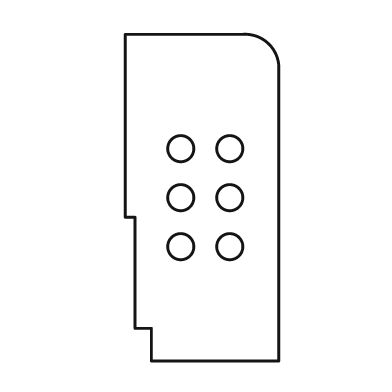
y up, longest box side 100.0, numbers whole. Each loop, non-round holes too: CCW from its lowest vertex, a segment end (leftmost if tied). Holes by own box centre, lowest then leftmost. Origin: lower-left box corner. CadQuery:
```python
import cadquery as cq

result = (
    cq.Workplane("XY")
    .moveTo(8.0, 0.0)
    .lineTo(47.0, 0.0)
    .lineTo(47.0, 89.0)
    .threePointArc((44.0, 97.0), (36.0, 100.0))
    .lineTo(0.0, 100.0)
    .lineTo(0.0, 44.0)
    .lineTo(3.0, 44.0)
    .lineTo(3.0, 10.0)
    .lineTo(8.0, 10.0)
    .close()
    .moveTo(17.0, 35.0)
    .circle(4.0)
    .moveTo(32.0, 35.0)
    .circle(4.0)
    .moveTo(17.0, 50.0)
    .circle(4.0)
    .moveTo(32.0, 50.0)
    .circle(4.0)
    .moveTo(17.0, 65.0)
    .circle(4.0)
    .moveTo(32.0, 65.0)
    .circle(4.0)
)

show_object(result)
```